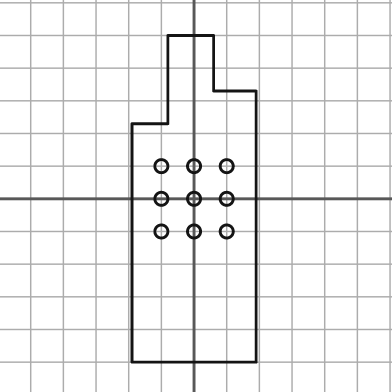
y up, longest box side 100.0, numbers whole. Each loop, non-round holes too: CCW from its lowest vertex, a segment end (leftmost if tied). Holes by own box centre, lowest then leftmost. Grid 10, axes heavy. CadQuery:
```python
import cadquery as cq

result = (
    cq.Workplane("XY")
    .moveTo(-19.0, -50.0)
    .lineTo(19.0, -50.0)
    .lineTo(19.0, 33.0)
    .lineTo(6.0, 33.0)
    .lineTo(6.0, 50.0)
    .lineTo(-8.0, 50.0)
    .lineTo(-8.0, 23.0)
    .lineTo(-19.0, 23.0)
    .close()
    .moveTo(-10.0, -10.0)
    .circle(2.0)
    .moveTo(0.0, -10.0)
    .circle(2.0)
    .moveTo(10.0, -10.0)
    .circle(2.0)
    .moveTo(-10.0, 0.0)
    .circle(2.0)
    .moveTo(0.0, 0.0)
    .circle(2.0)
    .moveTo(10.0, 0.0)
    .circle(2.0)
    .moveTo(-10.0, 10.0)
    .circle(2.0)
    .moveTo(0.0, 10.0)
    .circle(2.0)
    .moveTo(10.0, 10.0)
    .circle(2.0)
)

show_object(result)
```